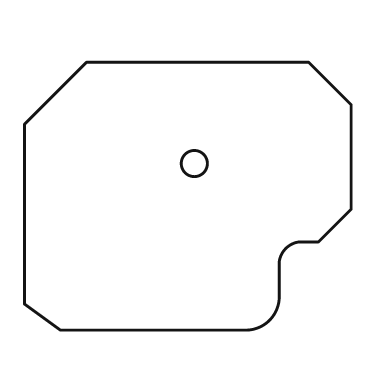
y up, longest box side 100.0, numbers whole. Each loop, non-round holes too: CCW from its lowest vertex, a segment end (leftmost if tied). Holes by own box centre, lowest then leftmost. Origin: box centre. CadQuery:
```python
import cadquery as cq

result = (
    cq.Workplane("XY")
    .moveTo(-39.0, -41.0)
    .lineTo(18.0, -41.0)
    .threePointArc((25.0, -38.0), (28.0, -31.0))
    .lineTo(28.0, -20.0)
    .threePointArc((30.0, -16.0), (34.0, -14.0))
    .lineTo(40.0, -14.0)
    .lineTo(50.0, -4.0)
    .lineTo(50.0, 28.0)
    .lineTo(37.0, 41.0)
    .lineTo(-31.0, 41.0)
    .lineTo(-50.0, 22.0)
    .lineTo(-50.0, -33.0)
    .close()
    .moveTo(2.0, 10.0)
    .circle(4.0)
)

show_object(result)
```